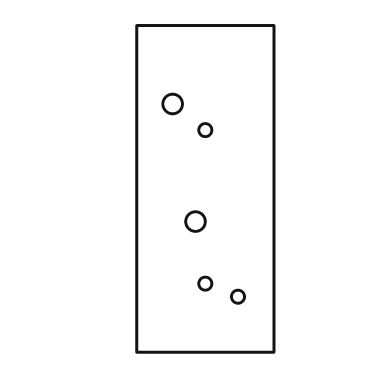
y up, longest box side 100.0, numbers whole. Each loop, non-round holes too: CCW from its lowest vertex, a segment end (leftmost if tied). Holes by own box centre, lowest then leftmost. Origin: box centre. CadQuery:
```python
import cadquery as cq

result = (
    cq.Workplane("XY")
    .moveTo(-21.0, -50.0)
    .lineTo(21.0, -50.0)
    .lineTo(21.0, 50.0)
    .lineTo(-21.0, 50.0)
    .close()
    .moveTo(10.0, -33.0)
    .circle(2.0)
    .moveTo(0.0, -29.0)
    .circle(2.0)
    .moveTo(-3.0, -10.0)
    .circle(3.0)
    .moveTo(0.0, 18.0)
    .circle(2.0)
    .moveTo(-10.0, 26.0)
    .circle(3.0)
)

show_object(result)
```